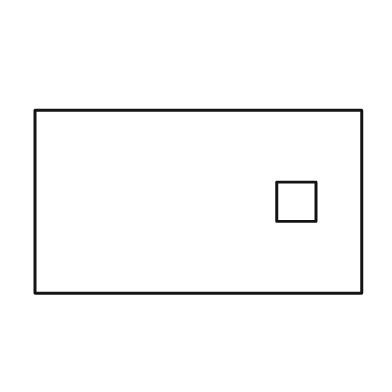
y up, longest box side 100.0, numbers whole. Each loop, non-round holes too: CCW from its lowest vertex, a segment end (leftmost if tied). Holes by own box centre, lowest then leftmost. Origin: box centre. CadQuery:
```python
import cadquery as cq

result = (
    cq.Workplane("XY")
    .moveTo(-50.0, -28.0)
    .lineTo(50.0, -28.0)
    .lineTo(50.0, 28.0)
    .lineTo(-50.0, 28.0)
    .close()
    .moveTo(24.0, -6.0)
    .lineTo(36.0, -6.0)
    .lineTo(36.0, 6.0)
    .lineTo(24.0, 6.0)
    .close()
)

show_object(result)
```